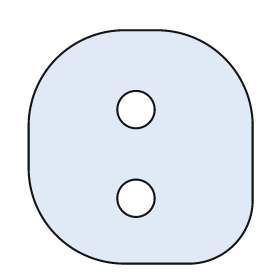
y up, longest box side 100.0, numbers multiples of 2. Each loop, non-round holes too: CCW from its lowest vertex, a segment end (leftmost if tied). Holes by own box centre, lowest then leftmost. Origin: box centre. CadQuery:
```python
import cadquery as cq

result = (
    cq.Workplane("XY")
    .moveTo(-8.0, -50.0)
    .lineTo(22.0, -50.0)
    .threePointArc((40.0, -42.0), (48.0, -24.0))
    .lineTo(48.0, 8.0)
    .threePointArc((36.0, 38.0), (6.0, 50.0))
    .lineTo(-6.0, 50.0)
    .threePointArc((-36.0, 38.0), (-48.0, 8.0))
    .lineTo(-48.0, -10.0)
    .threePointArc((-36.0, -38.0), (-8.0, -50.0))
    .close()
    .moveTo(-2.0, -22.0)
    .circle(8.0)
    .moveTo(-2.0, 16.0)
    .circle(8.0)
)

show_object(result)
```